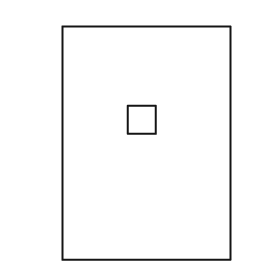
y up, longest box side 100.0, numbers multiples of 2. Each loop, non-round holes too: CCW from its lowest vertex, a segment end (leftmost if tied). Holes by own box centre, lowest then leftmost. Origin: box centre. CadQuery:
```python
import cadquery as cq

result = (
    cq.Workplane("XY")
    .moveTo(-36.0, -50.0)
    .lineTo(36.0, -50.0)
    .lineTo(36.0, 50.0)
    .lineTo(-36.0, 50.0)
    .close()
    .moveTo(-8.0, 4.0)
    .lineTo(4.0, 4.0)
    .lineTo(4.0, 16.0)
    .lineTo(-8.0, 16.0)
    .close()
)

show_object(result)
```